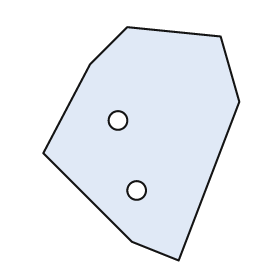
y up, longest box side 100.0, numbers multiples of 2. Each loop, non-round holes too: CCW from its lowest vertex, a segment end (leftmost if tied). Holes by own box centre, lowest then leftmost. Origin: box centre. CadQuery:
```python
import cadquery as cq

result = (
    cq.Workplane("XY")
    .moveTo(16.0, -50.0)
    .lineTo(42.0, 18.0)
    .lineTo(34.0, 46.0)
    .lineTo(-6.0, 50.0)
    .lineTo(-22.0, 34.0)
    .lineTo(-42.0, -4.0)
    .lineTo(-4.0, -42.0)
    .close()
    .moveTo(-2.0, -20.0)
    .circle(4.0)
    .moveTo(-10.0, 10.0)
    .circle(4.0)
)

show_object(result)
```